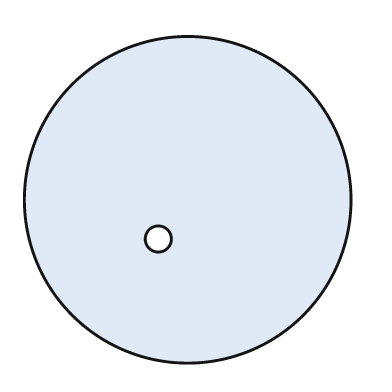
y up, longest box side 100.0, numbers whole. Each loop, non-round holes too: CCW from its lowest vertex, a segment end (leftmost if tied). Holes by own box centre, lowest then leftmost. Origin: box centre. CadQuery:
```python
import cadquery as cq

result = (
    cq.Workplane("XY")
    .moveTo(0.0, 0.0)
    .circle(50.0)
    .moveTo(-9.0, -12.0)
    .circle(4.0)
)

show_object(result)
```